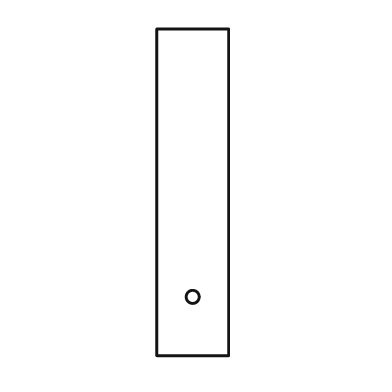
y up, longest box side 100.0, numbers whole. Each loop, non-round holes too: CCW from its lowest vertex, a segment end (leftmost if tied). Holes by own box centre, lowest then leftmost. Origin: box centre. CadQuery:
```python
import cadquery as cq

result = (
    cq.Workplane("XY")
    .moveTo(-11.0, -50.0)
    .lineTo(11.0, -50.0)
    .lineTo(11.0, 50.0)
    .lineTo(-11.0, 50.0)
    .close()
    .moveTo(0.0, -32.0)
    .circle(2.0)
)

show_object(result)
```